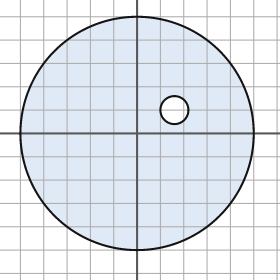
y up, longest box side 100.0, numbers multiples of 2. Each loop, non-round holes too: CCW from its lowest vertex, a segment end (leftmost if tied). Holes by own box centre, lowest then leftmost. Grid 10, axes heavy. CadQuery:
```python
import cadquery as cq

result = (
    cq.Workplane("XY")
    .moveTo(0.0, 0.0)
    .circle(50.0)
    .moveTo(16.0, 10.0)
    .circle(6.0)
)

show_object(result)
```